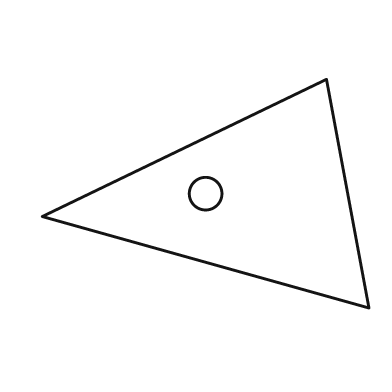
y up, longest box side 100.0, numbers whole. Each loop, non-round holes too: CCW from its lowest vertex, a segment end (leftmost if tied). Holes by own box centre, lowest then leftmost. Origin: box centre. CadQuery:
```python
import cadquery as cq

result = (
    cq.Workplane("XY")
    .moveTo(50.0, -35.0)
    .lineTo(37.0, 35.0)
    .lineTo(-50.0, -7.0)
    .close()
    .moveTo(0.0, 0.0)
    .circle(5.0)
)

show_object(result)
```